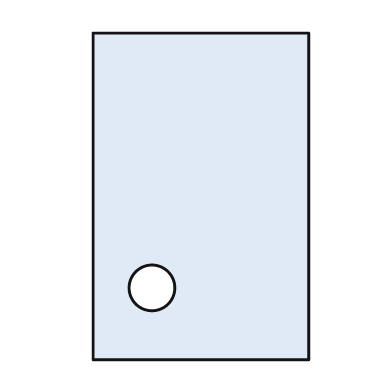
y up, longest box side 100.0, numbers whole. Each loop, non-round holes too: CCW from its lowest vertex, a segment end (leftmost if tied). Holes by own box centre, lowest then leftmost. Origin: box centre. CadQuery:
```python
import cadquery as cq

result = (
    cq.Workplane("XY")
    .moveTo(-33.0, -50.0)
    .lineTo(33.0, -50.0)
    .lineTo(33.0, 50.0)
    .lineTo(-33.0, 50.0)
    .close()
    .moveTo(-15.0, -28.0)
    .circle(7.0)
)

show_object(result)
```